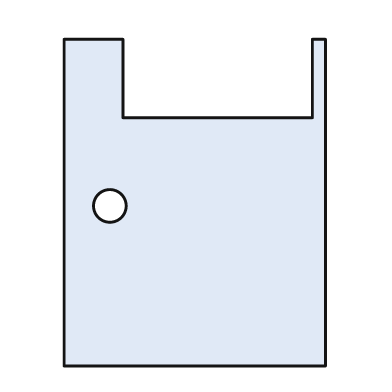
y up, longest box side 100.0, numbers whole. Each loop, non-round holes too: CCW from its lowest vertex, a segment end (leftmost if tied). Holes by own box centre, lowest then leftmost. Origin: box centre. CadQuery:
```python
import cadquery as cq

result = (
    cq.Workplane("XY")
    .moveTo(-40.0, -50.0)
    .lineTo(40.0, -50.0)
    .lineTo(40.0, 50.0)
    .lineTo(36.0, 50.0)
    .lineTo(36.0, 26.0)
    .lineTo(-22.0, 26.0)
    .lineTo(-22.0, 50.0)
    .lineTo(-40.0, 50.0)
    .close()
    .moveTo(-26.0, -1.0)
    .circle(5.0)
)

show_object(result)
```